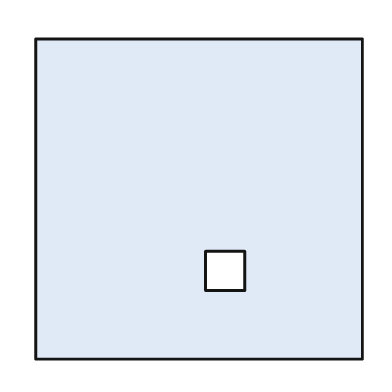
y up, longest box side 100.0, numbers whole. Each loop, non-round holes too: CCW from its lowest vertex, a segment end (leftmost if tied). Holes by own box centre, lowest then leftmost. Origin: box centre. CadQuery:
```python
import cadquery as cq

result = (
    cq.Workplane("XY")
    .moveTo(-50.0, -49.0)
    .lineTo(50.0, -49.0)
    .lineTo(50.0, 49.0)
    .lineTo(-50.0, 49.0)
    .close()
    .moveTo(2.0, -28.0)
    .lineTo(14.0, -28.0)
    .lineTo(14.0, -16.0)
    .lineTo(2.0, -16.0)
    .close()
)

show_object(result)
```